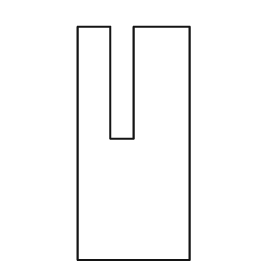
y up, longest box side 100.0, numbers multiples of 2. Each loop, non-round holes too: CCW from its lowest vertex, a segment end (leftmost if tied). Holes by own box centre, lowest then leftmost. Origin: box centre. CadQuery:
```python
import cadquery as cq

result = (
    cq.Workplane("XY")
    .moveTo(-24.0, -50.0)
    .lineTo(24.0, -50.0)
    .lineTo(24.0, 50.0)
    .lineTo(0.0, 50.0)
    .lineTo(0.0, 2.0)
    .lineTo(-10.0, 2.0)
    .lineTo(-10.0, 50.0)
    .lineTo(-24.0, 50.0)
    .close()
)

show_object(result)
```